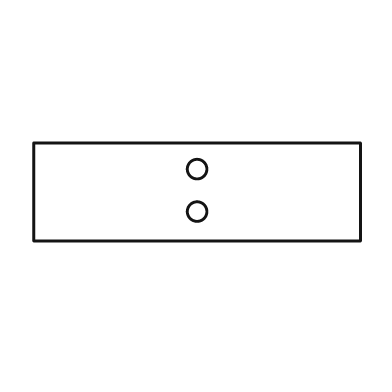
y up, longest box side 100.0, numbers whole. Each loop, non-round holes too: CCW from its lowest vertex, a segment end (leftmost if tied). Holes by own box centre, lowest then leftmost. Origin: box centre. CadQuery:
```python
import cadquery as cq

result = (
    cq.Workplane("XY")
    .moveTo(-50.0, -15.0)
    .lineTo(50.0, -15.0)
    .lineTo(50.0, 15.0)
    .lineTo(-50.0, 15.0)
    .close()
    .moveTo(0.0, -6.0)
    .circle(3.0)
    .moveTo(0.0, 7.0)
    .circle(3.0)
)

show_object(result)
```